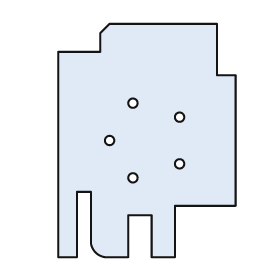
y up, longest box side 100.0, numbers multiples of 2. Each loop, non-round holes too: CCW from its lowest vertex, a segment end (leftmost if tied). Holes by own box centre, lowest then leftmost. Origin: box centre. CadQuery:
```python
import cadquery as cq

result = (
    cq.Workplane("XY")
    .moveTo(-38.0, -50.0)
    .lineTo(-30.0, -50.0)
    .lineTo(-30.0, -22.0)
    .lineTo(-24.0, -22.0)
    .lineTo(-24.0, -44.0)
    .threePointArc((-22.0, -48.0), (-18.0, -50.0))
    .lineTo(-8.0, -50.0)
    .lineTo(-8.0, -32.0)
    .lineTo(2.0, -32.0)
    .lineTo(2.0, -50.0)
    .lineTo(12.0, -50.0)
    .lineTo(12.0, -28.0)
    .lineTo(38.0, -28.0)
    .lineTo(38.0, 28.0)
    .lineTo(30.0, 28.0)
    .lineTo(30.0, 50.0)
    .lineTo(-16.0, 50.0)
    .lineTo(-20.0, 46.0)
    .lineTo(-20.0, 38.0)
    .lineTo(-38.0, 38.0)
    .close()
    .moveTo(-6.0, -16.0)
    .circle(2.0)
    .moveTo(14.0, -10.0)
    .circle(2.0)
    .moveTo(-16.0, 0.0)
    .circle(2.0)
    .moveTo(14.0, 10.0)
    .circle(2.0)
    .moveTo(-6.0, 16.0)
    .circle(2.0)
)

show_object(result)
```